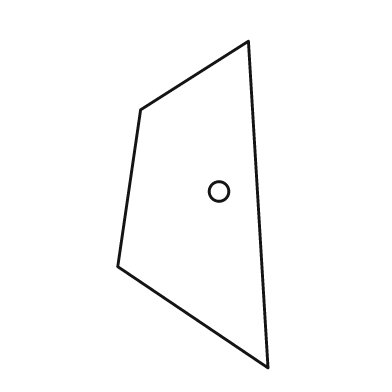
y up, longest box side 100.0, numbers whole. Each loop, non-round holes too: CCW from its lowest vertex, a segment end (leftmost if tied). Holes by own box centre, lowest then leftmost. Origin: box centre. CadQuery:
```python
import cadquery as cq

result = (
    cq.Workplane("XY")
    .moveTo(23.0, -50.0)
    .lineTo(17.0, 50.0)
    .lineTo(-16.0, 29.0)
    .lineTo(-23.0, -19.0)
    .close()
    .moveTo(8.0, 4.0)
    .circle(3.0)
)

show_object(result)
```